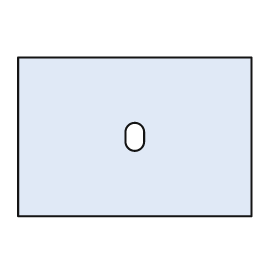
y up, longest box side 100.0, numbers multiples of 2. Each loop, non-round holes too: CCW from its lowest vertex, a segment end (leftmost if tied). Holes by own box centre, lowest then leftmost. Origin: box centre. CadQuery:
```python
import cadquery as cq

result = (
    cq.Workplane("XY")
    .moveTo(-50.0, -34.0)
    .lineTo(50.0, -34.0)
    .lineTo(50.0, 34.0)
    .lineTo(-50.0, 34.0)
    .close()
    .moveTo(-4.0, -2.0)
    .threePointArc((0.0, -6.0), (4.0, -2.0))
    .lineTo(4.0, 2.0)
    .threePointArc((0.0, 6.0), (-4.0, 2.0))
    .close()
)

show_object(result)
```